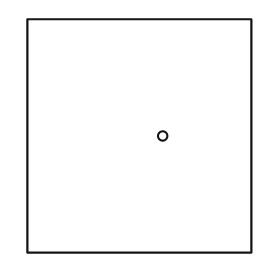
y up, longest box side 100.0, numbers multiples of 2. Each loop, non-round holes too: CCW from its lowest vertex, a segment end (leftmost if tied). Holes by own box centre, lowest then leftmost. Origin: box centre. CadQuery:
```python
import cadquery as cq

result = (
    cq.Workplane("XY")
    .moveTo(-48.0, -50.0)
    .lineTo(48.0, -50.0)
    .lineTo(48.0, 50.0)
    .lineTo(-48.0, 50.0)
    .close()
    .moveTo(10.0, 0.0)
    .circle(2.0)
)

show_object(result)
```